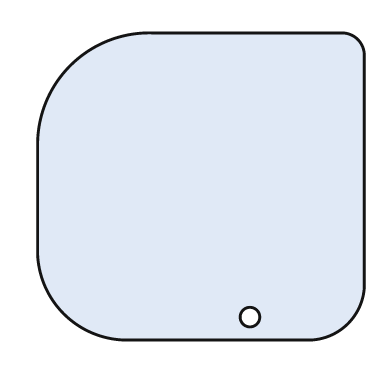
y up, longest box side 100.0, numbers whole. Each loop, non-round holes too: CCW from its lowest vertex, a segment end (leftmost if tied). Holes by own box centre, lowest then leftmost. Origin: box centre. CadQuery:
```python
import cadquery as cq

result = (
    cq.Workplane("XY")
    .moveTo(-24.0, -47.0)
    .lineTo(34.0, -47.0)
    .threePointArc((45.0, -42.0), (50.0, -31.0))
    .lineTo(50.0, 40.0)
    .threePointArc((48.0, 45.0), (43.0, 47.0))
    .lineTo(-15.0, 47.0)
    .threePointArc((-40.0, 37.0), (-50.0, 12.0))
    .lineTo(-50.0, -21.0)
    .threePointArc((-42.0, -39.0), (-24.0, -47.0))
    .close()
    .moveTo(15.0, -40.0)
    .circle(3.0)
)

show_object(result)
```